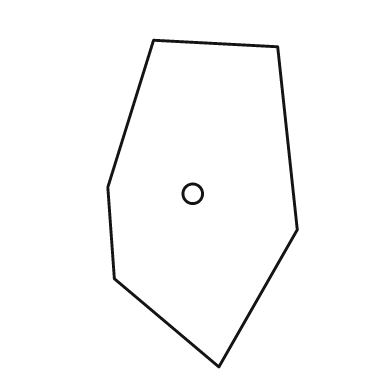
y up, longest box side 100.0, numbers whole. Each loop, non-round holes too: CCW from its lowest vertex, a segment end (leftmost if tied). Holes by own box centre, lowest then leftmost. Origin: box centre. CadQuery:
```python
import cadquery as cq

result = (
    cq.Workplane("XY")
    .moveTo(5.0, -50.0)
    .lineTo(29.0, -8.0)
    .lineTo(23.0, 48.0)
    .lineTo(-15.0, 50.0)
    .lineTo(-29.0, 5.0)
    .lineTo(-27.0, -23.0)
    .close()
    .moveTo(-3.0, 3.0)
    .circle(3.0)
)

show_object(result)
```